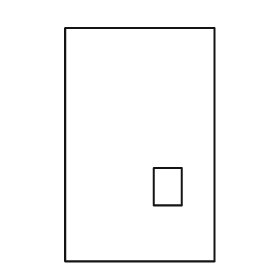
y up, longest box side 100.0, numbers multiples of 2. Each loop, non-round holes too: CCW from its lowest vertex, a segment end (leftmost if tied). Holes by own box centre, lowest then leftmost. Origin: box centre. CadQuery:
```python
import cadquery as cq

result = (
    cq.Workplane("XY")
    .moveTo(-32.0, -50.0)
    .lineTo(32.0, -50.0)
    .lineTo(32.0, 50.0)
    .lineTo(-32.0, 50.0)
    .close()
    .moveTo(6.0, -26.0)
    .lineTo(18.0, -26.0)
    .lineTo(18.0, -10.0)
    .lineTo(6.0, -10.0)
    .close()
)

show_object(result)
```